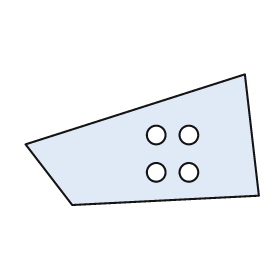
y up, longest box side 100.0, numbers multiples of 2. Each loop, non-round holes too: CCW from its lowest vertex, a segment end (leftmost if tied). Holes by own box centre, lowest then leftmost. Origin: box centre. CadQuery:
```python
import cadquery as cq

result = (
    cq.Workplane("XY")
    .moveTo(-30.0, -28.0)
    .lineTo(50.0, -24.0)
    .lineTo(44.0, 28.0)
    .lineTo(-50.0, -2.0)
    .close()
    .moveTo(6.0, -14.0)
    .circle(4.0)
    .moveTo(20.0, -14.0)
    .circle(4.0)
    .moveTo(6.0, 2.0)
    .circle(4.0)
    .moveTo(20.0, 2.0)
    .circle(4.0)
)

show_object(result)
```